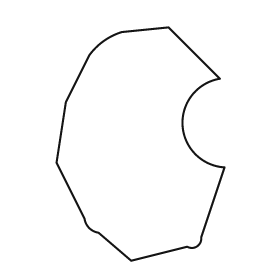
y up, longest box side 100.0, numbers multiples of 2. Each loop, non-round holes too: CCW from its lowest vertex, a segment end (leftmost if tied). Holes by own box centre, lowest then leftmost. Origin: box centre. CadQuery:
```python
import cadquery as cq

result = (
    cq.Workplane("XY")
    .moveTo(-4.0, -50.0)
    .lineTo(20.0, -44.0)
    .threePointArc((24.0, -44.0), (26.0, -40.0))
    .lineTo(36.0, -10.0)
    .threePointArc((18.0, 8.0), (34.0, 28.0))
    .lineTo(12.0, 50.0)
    .lineTo(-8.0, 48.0)
    .threePointArc((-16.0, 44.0), (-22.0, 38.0))
    .lineTo(-32.0, 18.0)
    .lineTo(-36.0, -8.0)
    .lineTo(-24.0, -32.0)
    .threePointArc((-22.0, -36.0), (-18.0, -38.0))
    .close()
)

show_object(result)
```